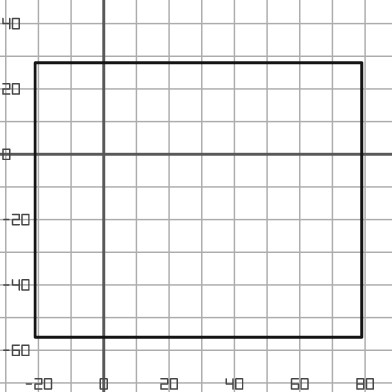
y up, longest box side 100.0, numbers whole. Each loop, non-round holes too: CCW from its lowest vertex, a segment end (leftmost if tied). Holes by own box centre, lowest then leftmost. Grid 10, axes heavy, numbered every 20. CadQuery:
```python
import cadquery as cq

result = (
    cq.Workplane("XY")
    .moveTo(-21.0, -56.0)
    .lineTo(79.0, -56.0)
    .lineTo(79.0, 28.0)
    .lineTo(-21.0, 28.0)
    .close()
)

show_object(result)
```